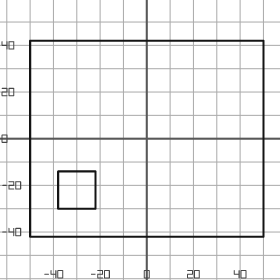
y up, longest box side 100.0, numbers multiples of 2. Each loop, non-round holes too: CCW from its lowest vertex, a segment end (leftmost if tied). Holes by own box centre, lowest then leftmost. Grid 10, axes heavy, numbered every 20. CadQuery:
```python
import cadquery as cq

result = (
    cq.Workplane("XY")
    .moveTo(-50.0, -42.0)
    .lineTo(50.0, -42.0)
    .lineTo(50.0, 42.0)
    .lineTo(-50.0, 42.0)
    .close()
    .moveTo(-38.0, -30.0)
    .lineTo(-22.0, -30.0)
    .lineTo(-22.0, -14.0)
    .lineTo(-38.0, -14.0)
    .close()
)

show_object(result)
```